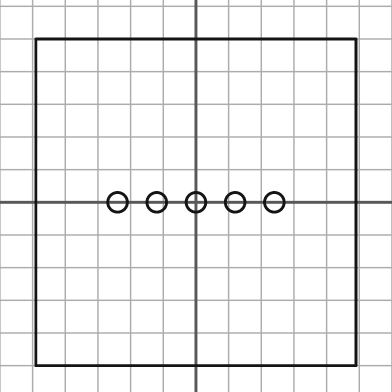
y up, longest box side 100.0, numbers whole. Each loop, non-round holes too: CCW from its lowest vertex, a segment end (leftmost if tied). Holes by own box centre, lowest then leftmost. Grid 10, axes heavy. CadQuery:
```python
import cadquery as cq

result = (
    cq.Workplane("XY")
    .moveTo(-49.0, -50.0)
    .lineTo(49.0, -50.0)
    .lineTo(49.0, 50.0)
    .lineTo(-49.0, 50.0)
    .close()
    .moveTo(-24.0, 0.0)
    .circle(3.0)
    .moveTo(-12.0, 0.0)
    .circle(3.0)
    .moveTo(0.0, 0.0)
    .circle(3.0)
    .moveTo(12.0, 0.0)
    .circle(3.0)
    .moveTo(24.0, 0.0)
    .circle(3.0)
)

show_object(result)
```